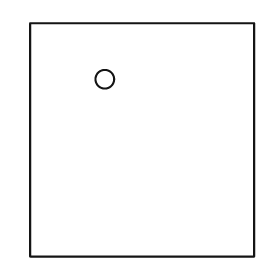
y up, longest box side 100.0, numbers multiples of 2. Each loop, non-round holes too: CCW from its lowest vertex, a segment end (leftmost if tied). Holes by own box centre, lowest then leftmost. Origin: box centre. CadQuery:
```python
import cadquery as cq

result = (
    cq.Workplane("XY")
    .moveTo(-48.0, -50.0)
    .lineTo(48.0, -50.0)
    .lineTo(48.0, 50.0)
    .lineTo(-48.0, 50.0)
    .close()
    .moveTo(-16.0, 26.0)
    .circle(4.0)
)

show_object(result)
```